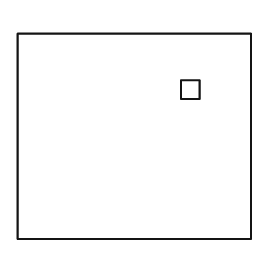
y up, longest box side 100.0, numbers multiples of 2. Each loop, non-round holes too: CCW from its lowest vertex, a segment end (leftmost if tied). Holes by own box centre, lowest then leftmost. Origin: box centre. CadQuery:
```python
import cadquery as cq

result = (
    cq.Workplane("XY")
    .moveTo(-50.0, -44.0)
    .lineTo(50.0, -44.0)
    .lineTo(50.0, 44.0)
    .lineTo(-50.0, 44.0)
    .close()
    .moveTo(20.0, 16.0)
    .lineTo(28.0, 16.0)
    .lineTo(28.0, 24.0)
    .lineTo(20.0, 24.0)
    .close()
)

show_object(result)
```